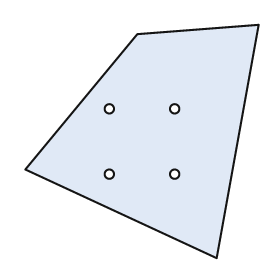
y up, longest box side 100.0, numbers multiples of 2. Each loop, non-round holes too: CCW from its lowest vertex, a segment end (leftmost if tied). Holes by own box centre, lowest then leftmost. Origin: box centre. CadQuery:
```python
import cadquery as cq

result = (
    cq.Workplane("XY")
    .moveTo(32.0, -50.0)
    .lineTo(50.0, 50.0)
    .lineTo(-2.0, 46.0)
    .lineTo(-50.0, -12.0)
    .close()
    .moveTo(-14.0, -14.0)
    .circle(2.0)
    .moveTo(14.0, -14.0)
    .circle(2.0)
    .moveTo(-14.0, 14.0)
    .circle(2.0)
    .moveTo(14.0, 14.0)
    .circle(2.0)
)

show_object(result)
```